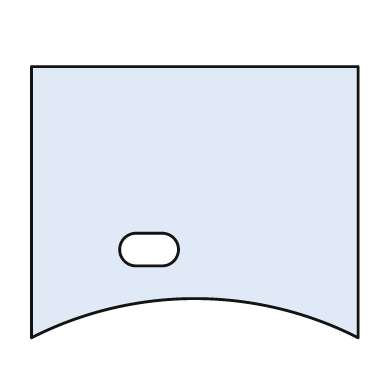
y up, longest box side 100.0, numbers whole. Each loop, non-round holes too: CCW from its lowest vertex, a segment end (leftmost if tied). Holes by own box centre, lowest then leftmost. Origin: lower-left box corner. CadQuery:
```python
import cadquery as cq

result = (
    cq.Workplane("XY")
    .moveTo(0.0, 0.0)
    .threePointArc((50.0, 12.0), (100.0, 0.0))
    .lineTo(100.0, 83.0)
    .lineTo(0.0, 83.0)
    .close()
    .moveTo(32.0, 22.0)
    .lineTo(40.0, 22.0)
    .threePointArc((45.0, 27.0), (40.0, 32.0))
    .lineTo(32.0, 32.0)
    .threePointArc((27.0, 27.0), (32.0, 22.0))
    .close()
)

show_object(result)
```